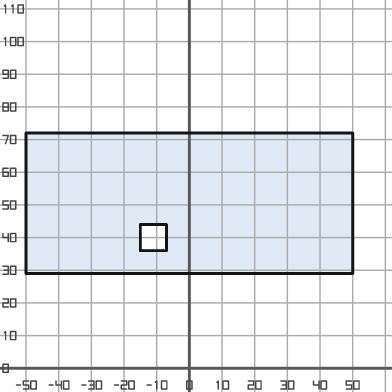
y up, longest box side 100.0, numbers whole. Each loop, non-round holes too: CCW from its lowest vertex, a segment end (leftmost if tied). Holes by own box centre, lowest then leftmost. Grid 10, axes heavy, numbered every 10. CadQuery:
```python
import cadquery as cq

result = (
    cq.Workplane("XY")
    .moveTo(-50.0, 29.0)
    .lineTo(50.0, 29.0)
    .lineTo(50.0, 72.0)
    .lineTo(-50.0, 72.0)
    .close()
    .moveTo(-15.0, 36.0)
    .lineTo(-7.0, 36.0)
    .lineTo(-7.0, 44.0)
    .lineTo(-15.0, 44.0)
    .close()
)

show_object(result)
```